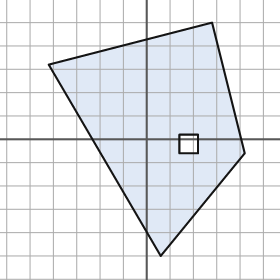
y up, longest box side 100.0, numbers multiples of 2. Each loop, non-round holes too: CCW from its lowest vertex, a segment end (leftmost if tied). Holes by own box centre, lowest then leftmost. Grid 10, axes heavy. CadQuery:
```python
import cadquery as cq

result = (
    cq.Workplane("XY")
    .moveTo(6.0, -50.0)
    .lineTo(42.0, -6.0)
    .lineTo(28.0, 50.0)
    .lineTo(-42.0, 32.0)
    .close()
    .moveTo(14.0, -6.0)
    .lineTo(22.0, -6.0)
    .lineTo(22.0, 2.0)
    .lineTo(14.0, 2.0)
    .close()
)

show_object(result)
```